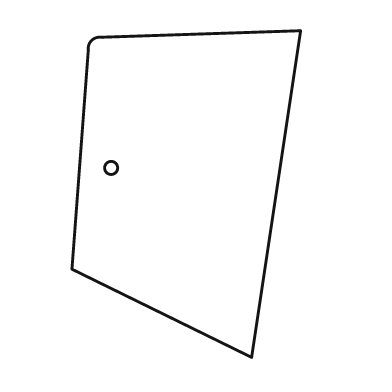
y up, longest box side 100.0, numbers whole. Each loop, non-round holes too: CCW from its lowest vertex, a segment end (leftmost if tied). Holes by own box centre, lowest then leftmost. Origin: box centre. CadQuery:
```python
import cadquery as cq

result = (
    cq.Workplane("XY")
    .moveTo(20.0, -50.0)
    .lineTo(35.0, 50.0)
    .lineTo(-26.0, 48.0)
    .threePointArc((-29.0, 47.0), (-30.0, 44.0))
    .lineTo(-35.0, -23.0)
    .close()
    .moveTo(-23.0, 8.0)
    .circle(2.0)
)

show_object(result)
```